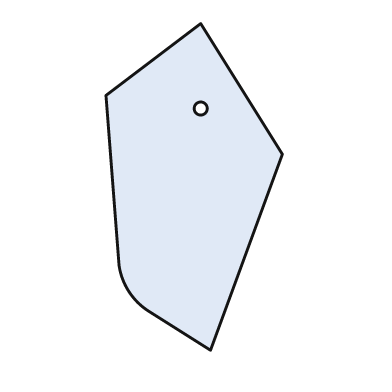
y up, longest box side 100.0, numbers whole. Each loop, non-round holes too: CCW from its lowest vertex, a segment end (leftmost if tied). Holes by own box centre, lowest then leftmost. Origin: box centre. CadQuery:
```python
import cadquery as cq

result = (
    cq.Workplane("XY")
    .moveTo(5.0, -50.0)
    .lineTo(27.0, 10.0)
    .lineTo(2.0, 50.0)
    .lineTo(-27.0, 28.0)
    .lineTo(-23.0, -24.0)
    .threePointArc((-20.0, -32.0), (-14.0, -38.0))
    .close()
    .moveTo(2.0, 24.0)
    .circle(2.0)
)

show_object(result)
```